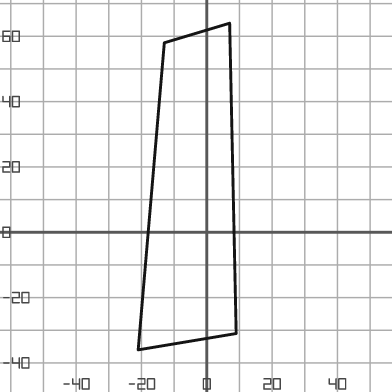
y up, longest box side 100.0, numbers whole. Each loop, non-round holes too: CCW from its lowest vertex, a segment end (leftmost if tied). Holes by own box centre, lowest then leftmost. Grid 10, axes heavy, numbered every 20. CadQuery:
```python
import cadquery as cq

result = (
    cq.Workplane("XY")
    .moveTo(-21.0, -36.0)
    .lineTo(9.0, -31.0)
    .lineTo(7.0, 64.0)
    .lineTo(-13.0, 58.0)
    .close()
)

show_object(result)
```